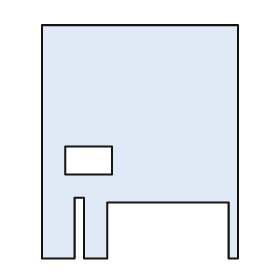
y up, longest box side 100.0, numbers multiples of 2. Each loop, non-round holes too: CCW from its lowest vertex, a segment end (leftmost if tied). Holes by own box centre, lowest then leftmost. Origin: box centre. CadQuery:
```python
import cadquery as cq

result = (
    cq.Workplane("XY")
    .moveTo(-42.0, -50.0)
    .lineTo(-28.0, -50.0)
    .lineTo(-28.0, -24.0)
    .lineTo(-24.0, -24.0)
    .lineTo(-24.0, -50.0)
    .lineTo(-14.0, -50.0)
    .lineTo(-14.0, -26.0)
    .lineTo(38.0, -26.0)
    .lineTo(38.0, -50.0)
    .lineTo(42.0, -50.0)
    .lineTo(42.0, 50.0)
    .lineTo(-42.0, 50.0)
    .close()
    .moveTo(-32.0, -14.0)
    .lineTo(-12.0, -14.0)
    .lineTo(-12.0, -2.0)
    .lineTo(-32.0, -2.0)
    .close()
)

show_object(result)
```